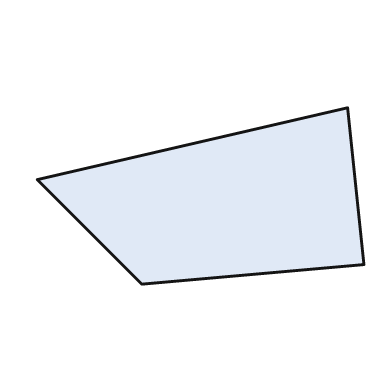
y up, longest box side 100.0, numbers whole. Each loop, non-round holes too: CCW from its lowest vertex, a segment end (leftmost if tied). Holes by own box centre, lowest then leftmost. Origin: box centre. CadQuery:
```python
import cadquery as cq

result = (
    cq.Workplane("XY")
    .moveTo(-18.0, -27.0)
    .lineTo(50.0, -21.0)
    .lineTo(45.0, 27.0)
    .lineTo(-50.0, 5.0)
    .close()
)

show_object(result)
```